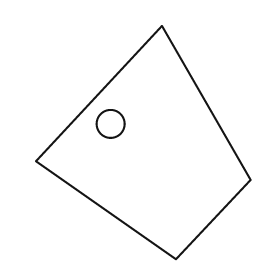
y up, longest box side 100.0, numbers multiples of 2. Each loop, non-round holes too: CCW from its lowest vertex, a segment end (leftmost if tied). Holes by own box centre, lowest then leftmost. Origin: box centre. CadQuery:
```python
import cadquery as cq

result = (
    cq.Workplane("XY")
    .moveTo(14.0, -50.0)
    .lineTo(46.0, -16.0)
    .lineTo(8.0, 50.0)
    .lineTo(-46.0, -8.0)
    .close()
    .moveTo(-14.0, 8.0)
    .circle(6.0)
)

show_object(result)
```